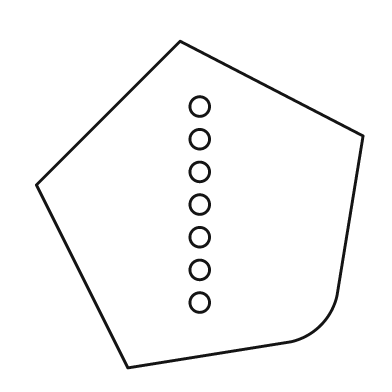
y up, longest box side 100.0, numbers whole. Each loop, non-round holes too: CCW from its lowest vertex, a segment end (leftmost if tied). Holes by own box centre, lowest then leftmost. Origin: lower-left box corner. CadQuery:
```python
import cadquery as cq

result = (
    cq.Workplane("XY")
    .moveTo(28.0, 0.0)
    .lineTo(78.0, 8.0)
    .threePointArc((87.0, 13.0), (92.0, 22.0))
    .lineTo(100.0, 71.0)
    .lineTo(44.0, 100.0)
    .lineTo(0.0, 56.0)
    .close()
    .moveTo(50.0, 20.0)
    .circle(3.0)
    .moveTo(50.0, 30.0)
    .circle(3.0)
    .moveTo(50.0, 40.0)
    .circle(3.0)
    .moveTo(50.0, 50.0)
    .circle(3.0)
    .moveTo(50.0, 60.0)
    .circle(3.0)
    .moveTo(50.0, 70.0)
    .circle(3.0)
    .moveTo(50.0, 80.0)
    .circle(3.0)
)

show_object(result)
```